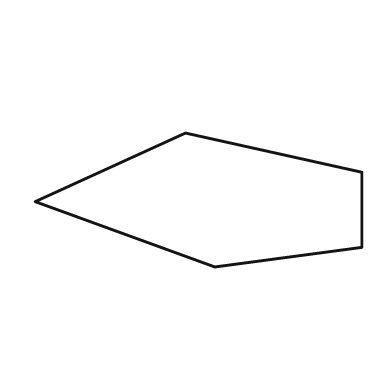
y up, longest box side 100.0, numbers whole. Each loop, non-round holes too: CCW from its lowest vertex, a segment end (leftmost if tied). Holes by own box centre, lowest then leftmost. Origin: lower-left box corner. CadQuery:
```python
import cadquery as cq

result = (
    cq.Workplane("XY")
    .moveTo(55.0, 0.0)
    .lineTo(100.0, 6.0)
    .lineTo(100.0, 29.0)
    .lineTo(46.0, 41.0)
    .lineTo(0.0, 20.0)
    .close()
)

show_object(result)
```